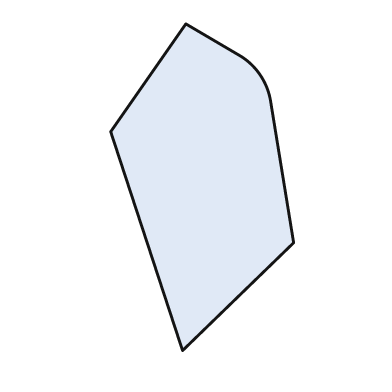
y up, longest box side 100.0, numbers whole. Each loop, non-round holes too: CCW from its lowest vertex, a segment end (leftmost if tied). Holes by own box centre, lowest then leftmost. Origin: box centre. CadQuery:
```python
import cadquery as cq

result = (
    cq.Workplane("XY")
    .moveTo(-6.0, -50.0)
    .lineTo(28.0, -17.0)
    .lineTo(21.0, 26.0)
    .threePointArc((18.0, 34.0), (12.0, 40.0))
    .lineTo(-5.0, 50.0)
    .lineTo(-28.0, 17.0)
    .close()
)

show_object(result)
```